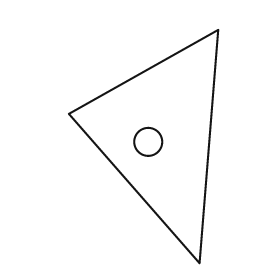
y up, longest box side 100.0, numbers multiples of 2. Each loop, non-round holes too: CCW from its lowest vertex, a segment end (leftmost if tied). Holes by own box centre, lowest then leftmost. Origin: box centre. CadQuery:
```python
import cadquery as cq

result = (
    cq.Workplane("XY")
    .moveTo(24.0, -50.0)
    .lineTo(32.0, 50.0)
    .lineTo(-32.0, 14.0)
    .close()
    .moveTo(2.0, 2.0)
    .circle(6.0)
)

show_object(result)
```